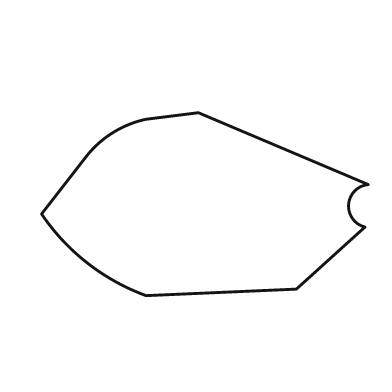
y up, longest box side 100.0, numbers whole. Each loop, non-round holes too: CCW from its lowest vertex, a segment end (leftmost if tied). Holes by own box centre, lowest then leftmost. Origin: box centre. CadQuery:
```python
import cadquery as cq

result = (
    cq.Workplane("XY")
    .moveTo(-18.0, -28.0)
    .lineTo(28.0, -26.0)
    .lineTo(49.0, -7.0)
    .threePointArc((44.0, 0.0), (50.0, 6.0))
    .lineTo(-2.0, 28.0)
    .lineTo(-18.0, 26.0)
    .threePointArc((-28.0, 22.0), (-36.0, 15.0))
    .lineTo(-50.0, -3.0)
    .threePointArc((-36.0, -18.0), (-18.0, -28.0))
    .close()
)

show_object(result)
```